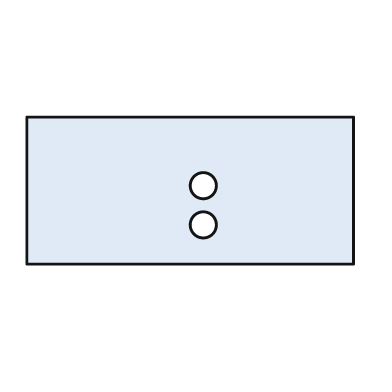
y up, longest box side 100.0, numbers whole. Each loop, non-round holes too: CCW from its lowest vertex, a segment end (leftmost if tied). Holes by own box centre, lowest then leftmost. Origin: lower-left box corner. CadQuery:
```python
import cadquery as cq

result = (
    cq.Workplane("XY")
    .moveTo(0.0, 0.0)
    .lineTo(100.0, 0.0)
    .lineTo(100.0, 45.0)
    .lineTo(0.0, 45.0)
    .close()
    .moveTo(54.0, 12.0)
    .circle(4.0)
    .moveTo(54.0, 24.0)
    .circle(4.0)
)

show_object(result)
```